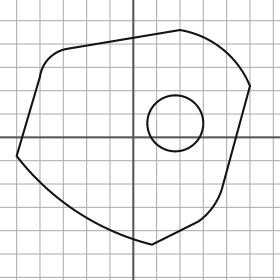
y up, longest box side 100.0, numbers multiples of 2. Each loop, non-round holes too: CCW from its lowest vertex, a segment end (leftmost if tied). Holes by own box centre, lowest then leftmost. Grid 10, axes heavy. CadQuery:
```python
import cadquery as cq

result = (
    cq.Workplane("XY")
    .moveTo(8.0, -46.0)
    .lineTo(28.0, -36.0)
    .threePointArc((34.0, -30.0), (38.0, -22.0))
    .lineTo(50.0, 22.0)
    .threePointArc((38.0, 38.0), (20.0, 46.0))
    .lineTo(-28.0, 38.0)
    .threePointArc((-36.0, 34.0), (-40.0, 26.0))
    .lineTo(-50.0, -8.0)
    .threePointArc((-24.0, -32.0), (8.0, -46.0))
    .close()
    .moveTo(18.0, 6.0)
    .circle(12.0)
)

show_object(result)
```